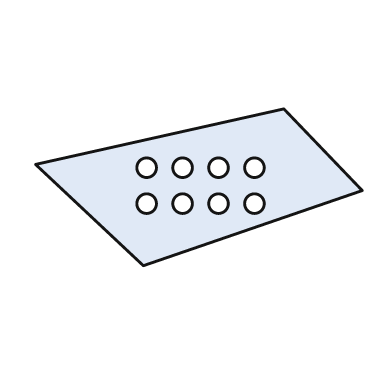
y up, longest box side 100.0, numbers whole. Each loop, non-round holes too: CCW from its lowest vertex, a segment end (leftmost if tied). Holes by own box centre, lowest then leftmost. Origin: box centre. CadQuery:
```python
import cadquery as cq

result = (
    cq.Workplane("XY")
    .moveTo(-17.0, -24.0)
    .lineTo(50.0, -1.0)
    .lineTo(26.0, 24.0)
    .lineTo(-50.0, 7.0)
    .close()
    .moveTo(-16.0, -5.0)
    .circle(3.0)
    .moveTo(-5.0, -5.0)
    .circle(3.0)
    .moveTo(6.0, -5.0)
    .circle(3.0)
    .moveTo(17.0, -5.0)
    .circle(3.0)
    .moveTo(-16.0, 6.0)
    .circle(3.0)
    .moveTo(-5.0, 6.0)
    .circle(3.0)
    .moveTo(6.0, 6.0)
    .circle(3.0)
    .moveTo(17.0, 6.0)
    .circle(3.0)
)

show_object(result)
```